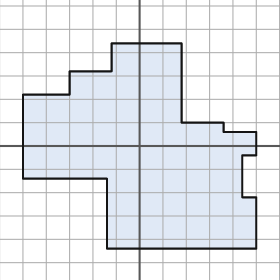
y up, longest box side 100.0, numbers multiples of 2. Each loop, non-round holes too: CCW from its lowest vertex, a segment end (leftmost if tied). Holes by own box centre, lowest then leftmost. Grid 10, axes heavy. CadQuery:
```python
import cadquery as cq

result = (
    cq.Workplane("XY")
    .moveTo(-14.0, -44.0)
    .lineTo(50.0, -44.0)
    .lineTo(50.0, -22.0)
    .lineTo(44.0, -22.0)
    .lineTo(44.0, -4.0)
    .lineTo(50.0, -4.0)
    .lineTo(50.0, 6.0)
    .lineTo(36.0, 6.0)
    .lineTo(36.0, 10.0)
    .lineTo(18.0, 10.0)
    .lineTo(18.0, 44.0)
    .lineTo(-12.0, 44.0)
    .lineTo(-12.0, 32.0)
    .lineTo(-30.0, 32.0)
    .lineTo(-30.0, 22.0)
    .lineTo(-50.0, 22.0)
    .lineTo(-50.0, -14.0)
    .lineTo(-14.0, -14.0)
    .close()
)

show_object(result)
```